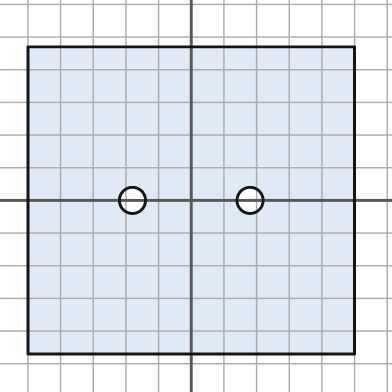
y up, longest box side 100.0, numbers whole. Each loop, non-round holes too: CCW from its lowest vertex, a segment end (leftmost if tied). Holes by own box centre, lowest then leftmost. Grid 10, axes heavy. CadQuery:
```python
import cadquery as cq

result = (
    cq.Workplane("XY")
    .moveTo(-50.0, -47.0)
    .lineTo(50.0, -47.0)
    .lineTo(50.0, 47.0)
    .lineTo(-50.0, 47.0)
    .close()
    .moveTo(-18.0, 0.0)
    .circle(4.0)
    .moveTo(18.0, 0.0)
    .circle(4.0)
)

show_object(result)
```